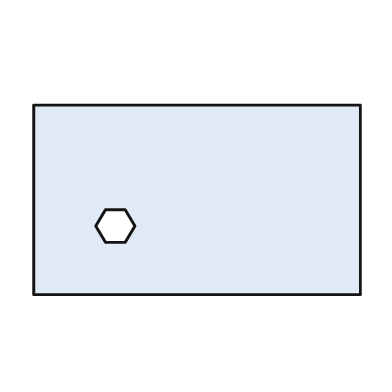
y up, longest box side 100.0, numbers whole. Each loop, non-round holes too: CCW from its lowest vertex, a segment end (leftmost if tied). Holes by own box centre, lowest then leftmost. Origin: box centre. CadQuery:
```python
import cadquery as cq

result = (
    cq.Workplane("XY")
    .moveTo(-50.0, -29.0)
    .lineTo(50.0, -29.0)
    .lineTo(50.0, 29.0)
    .lineTo(-50.0, 29.0)
    .close()
    .moveTo(-28.0, -13.0)
    .lineTo(-22.0, -13.0)
    .lineTo(-19.0, -8.0)
    .lineTo(-22.0, -3.0)
    .lineTo(-28.0, -3.0)
    .lineTo(-31.0, -8.0)
    .close()
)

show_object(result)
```